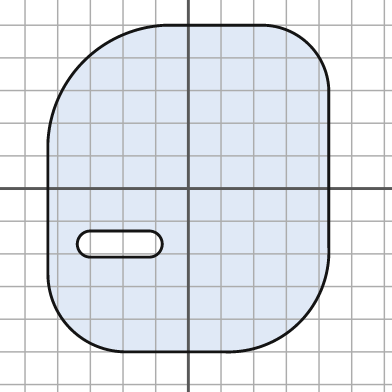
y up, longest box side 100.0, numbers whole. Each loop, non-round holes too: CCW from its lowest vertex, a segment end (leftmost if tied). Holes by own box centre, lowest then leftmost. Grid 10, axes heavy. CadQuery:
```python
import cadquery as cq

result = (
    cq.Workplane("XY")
    .moveTo(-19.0, -50.0)
    .lineTo(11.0, -50.0)
    .threePointArc((34.0, -41.0), (43.0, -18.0))
    .lineTo(43.0, 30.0)
    .threePointArc((37.0, 44.0), (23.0, 50.0))
    .lineTo(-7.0, 50.0)
    .threePointArc((-32.0, 39.0), (-43.0, 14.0))
    .lineTo(-43.0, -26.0)
    .threePointArc((-36.0, -43.0), (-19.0, -50.0))
    .close()
    .moveTo(-30.0, -21.0)
    .lineTo(-12.0, -21.0)
    .threePointArc((-8.0, -17.0), (-12.0, -13.0))
    .lineTo(-30.0, -13.0)
    .threePointArc((-34.0, -17.0), (-30.0, -21.0))
    .close()
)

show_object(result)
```